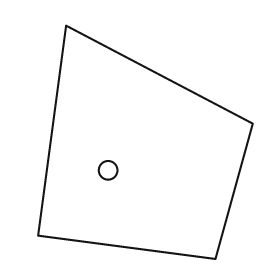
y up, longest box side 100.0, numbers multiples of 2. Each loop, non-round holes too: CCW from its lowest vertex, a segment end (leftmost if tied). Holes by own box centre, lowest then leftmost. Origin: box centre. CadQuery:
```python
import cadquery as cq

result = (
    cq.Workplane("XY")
    .moveTo(30.0, -50.0)
    .lineTo(46.0, 8.0)
    .lineTo(-34.0, 50.0)
    .lineTo(-46.0, -40.0)
    .close()
    .moveTo(-16.0, -12.0)
    .circle(4.0)
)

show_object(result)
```